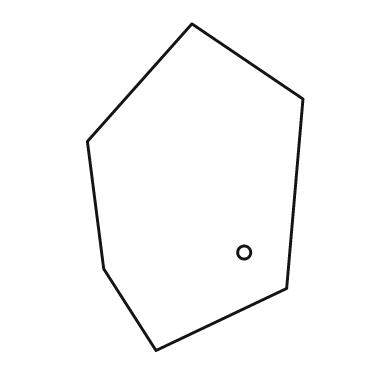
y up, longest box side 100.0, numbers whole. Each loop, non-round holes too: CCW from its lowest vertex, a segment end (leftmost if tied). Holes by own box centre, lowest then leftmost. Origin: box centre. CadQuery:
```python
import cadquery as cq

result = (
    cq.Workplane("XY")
    .moveTo(-12.0, -50.0)
    .lineTo(28.0, -31.0)
    .lineTo(33.0, 27.0)
    .lineTo(-1.0, 50.0)
    .lineTo(-33.0, 14.0)
    .lineTo(-28.0, -25.0)
    .close()
    .moveTo(15.0, -20.0)
    .circle(2.0)
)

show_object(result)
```